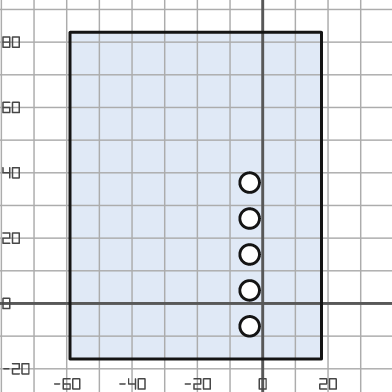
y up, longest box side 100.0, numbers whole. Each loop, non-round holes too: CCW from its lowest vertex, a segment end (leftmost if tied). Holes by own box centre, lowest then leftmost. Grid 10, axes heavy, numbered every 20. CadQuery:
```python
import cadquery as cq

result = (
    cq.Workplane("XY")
    .moveTo(-59.0, -17.0)
    .lineTo(18.0, -17.0)
    .lineTo(18.0, 83.0)
    .lineTo(-59.0, 83.0)
    .close()
    .moveTo(-4.0, -7.0)
    .circle(3.0)
    .moveTo(-4.0, 4.0)
    .circle(3.0)
    .moveTo(-4.0, 15.0)
    .circle(3.0)
    .moveTo(-4.0, 26.0)
    .circle(3.0)
    .moveTo(-4.0, 37.0)
    .circle(3.0)
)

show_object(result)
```